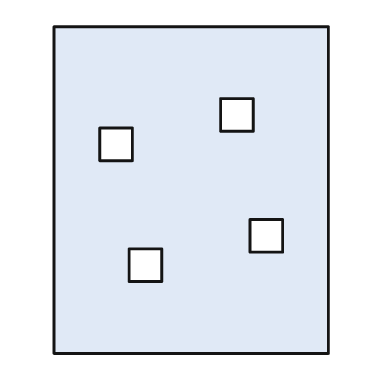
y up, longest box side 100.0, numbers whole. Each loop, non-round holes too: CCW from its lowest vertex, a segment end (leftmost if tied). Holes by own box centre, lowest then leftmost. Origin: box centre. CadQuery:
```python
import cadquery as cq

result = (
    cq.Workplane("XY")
    .moveTo(-42.0, -50.0)
    .lineTo(42.0, -50.0)
    .lineTo(42.0, 50.0)
    .lineTo(-42.0, 50.0)
    .close()
    .moveTo(-19.0, -28.0)
    .lineTo(-9.0, -28.0)
    .lineTo(-9.0, -18.0)
    .lineTo(-19.0, -18.0)
    .close()
    .moveTo(18.0, -19.0)
    .lineTo(28.0, -19.0)
    .lineTo(28.0, -9.0)
    .lineTo(18.0, -9.0)
    .close()
    .moveTo(-28.0, 9.0)
    .lineTo(-18.0, 9.0)
    .lineTo(-18.0, 19.0)
    .lineTo(-28.0, 19.0)
    .close()
    .moveTo(9.0, 18.0)
    .lineTo(19.0, 18.0)
    .lineTo(19.0, 28.0)
    .lineTo(9.0, 28.0)
    .close()
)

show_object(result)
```